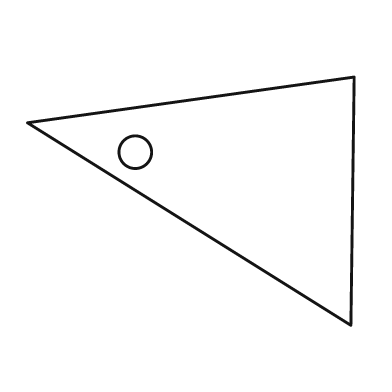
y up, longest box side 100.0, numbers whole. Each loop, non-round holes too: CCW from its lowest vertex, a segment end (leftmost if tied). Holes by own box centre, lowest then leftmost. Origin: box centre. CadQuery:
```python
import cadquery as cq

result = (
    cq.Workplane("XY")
    .moveTo(49.0, -38.0)
    .lineTo(50.0, 38.0)
    .lineTo(-50.0, 24.0)
    .close()
    .moveTo(-17.0, 15.0)
    .circle(5.0)
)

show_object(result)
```